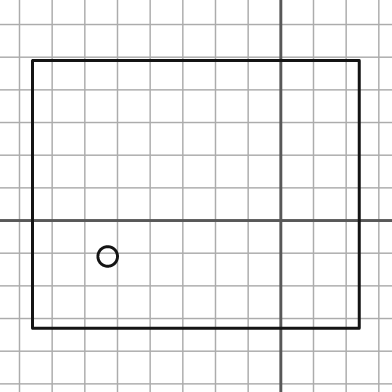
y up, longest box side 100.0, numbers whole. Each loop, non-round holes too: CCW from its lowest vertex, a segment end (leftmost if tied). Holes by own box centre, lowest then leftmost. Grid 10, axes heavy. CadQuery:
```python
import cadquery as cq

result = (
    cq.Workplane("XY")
    .moveTo(-76.0, -33.0)
    .lineTo(24.0, -33.0)
    .lineTo(24.0, 49.0)
    .lineTo(-76.0, 49.0)
    .close()
    .moveTo(-53.0, -11.0)
    .circle(3.0)
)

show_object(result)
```